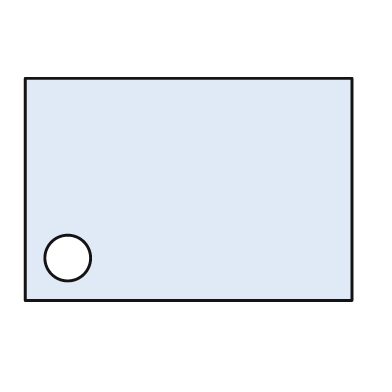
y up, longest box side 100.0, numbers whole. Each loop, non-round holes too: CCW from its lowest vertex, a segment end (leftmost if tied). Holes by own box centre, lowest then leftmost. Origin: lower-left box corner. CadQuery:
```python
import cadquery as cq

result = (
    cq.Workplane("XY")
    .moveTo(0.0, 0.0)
    .lineTo(100.0, 0.0)
    .lineTo(100.0, 68.0)
    .lineTo(0.0, 68.0)
    .close()
    .moveTo(13.0, 13.0)
    .circle(7.0)
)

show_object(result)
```